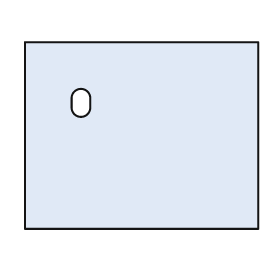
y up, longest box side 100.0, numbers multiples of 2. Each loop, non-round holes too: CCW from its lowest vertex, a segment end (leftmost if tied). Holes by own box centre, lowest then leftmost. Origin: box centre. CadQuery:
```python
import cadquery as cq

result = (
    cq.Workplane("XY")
    .moveTo(-50.0, -40.0)
    .lineTo(50.0, -40.0)
    .lineTo(50.0, 40.0)
    .lineTo(-50.0, 40.0)
    .close()
    .moveTo(-30.0, 12.0)
    .threePointArc((-26.0, 8.0), (-22.0, 12.0))
    .lineTo(-22.0, 16.0)
    .threePointArc((-26.0, 20.0), (-30.0, 16.0))
    .close()
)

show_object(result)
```